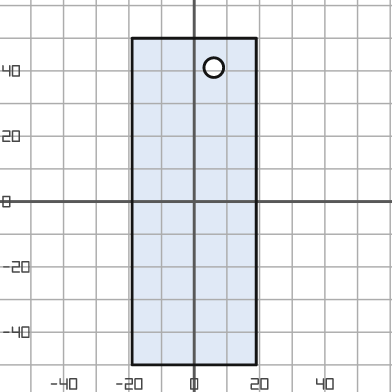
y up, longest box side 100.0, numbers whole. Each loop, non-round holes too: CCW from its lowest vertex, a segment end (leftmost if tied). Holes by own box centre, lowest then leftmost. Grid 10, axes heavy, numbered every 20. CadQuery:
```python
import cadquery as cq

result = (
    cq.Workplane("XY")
    .moveTo(-19.0, -50.0)
    .lineTo(19.0, -50.0)
    .lineTo(19.0, 50.0)
    .lineTo(-19.0, 50.0)
    .close()
    .moveTo(6.0, 41.0)
    .circle(3.0)
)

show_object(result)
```